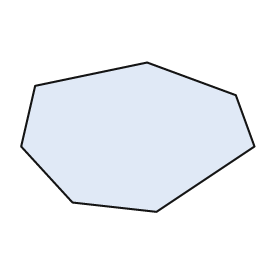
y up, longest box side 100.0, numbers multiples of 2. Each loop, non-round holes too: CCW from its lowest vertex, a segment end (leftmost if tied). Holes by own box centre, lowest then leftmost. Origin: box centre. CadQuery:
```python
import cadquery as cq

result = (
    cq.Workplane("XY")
    .moveTo(8.0, -32.0)
    .lineTo(50.0, -4.0)
    .lineTo(42.0, 18.0)
    .lineTo(4.0, 32.0)
    .lineTo(-44.0, 22.0)
    .lineTo(-50.0, -4.0)
    .lineTo(-28.0, -28.0)
    .close()
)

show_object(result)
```